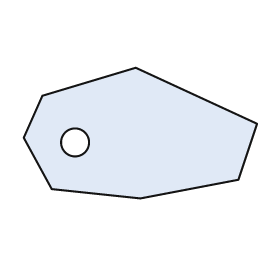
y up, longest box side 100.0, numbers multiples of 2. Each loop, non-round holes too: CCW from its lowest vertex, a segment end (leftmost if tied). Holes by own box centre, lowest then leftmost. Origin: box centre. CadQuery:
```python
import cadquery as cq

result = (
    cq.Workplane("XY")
    .moveTo(0.0, -28.0)
    .lineTo(42.0, -20.0)
    .lineTo(50.0, 4.0)
    .lineTo(-2.0, 28.0)
    .lineTo(-42.0, 16.0)
    .lineTo(-50.0, -2.0)
    .lineTo(-38.0, -24.0)
    .close()
    .moveTo(-28.0, -4.0)
    .circle(6.0)
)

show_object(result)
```